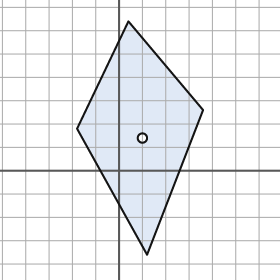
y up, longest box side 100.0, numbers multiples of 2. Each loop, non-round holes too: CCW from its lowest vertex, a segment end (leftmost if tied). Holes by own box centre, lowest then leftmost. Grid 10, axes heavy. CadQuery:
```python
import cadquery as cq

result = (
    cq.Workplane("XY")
    .moveTo(12.0, -36.0)
    .lineTo(36.0, 26.0)
    .lineTo(4.0, 64.0)
    .lineTo(-18.0, 18.0)
    .close()
    .moveTo(10.0, 14.0)
    .circle(2.0)
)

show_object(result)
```